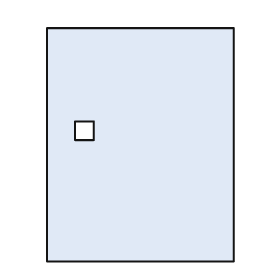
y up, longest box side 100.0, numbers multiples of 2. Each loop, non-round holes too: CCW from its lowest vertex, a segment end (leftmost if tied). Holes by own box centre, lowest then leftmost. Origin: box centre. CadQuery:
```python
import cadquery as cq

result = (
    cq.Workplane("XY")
    .moveTo(-40.0, -50.0)
    .lineTo(40.0, -50.0)
    .lineTo(40.0, 50.0)
    .lineTo(-40.0, 50.0)
    .close()
    .moveTo(-28.0, 2.0)
    .lineTo(-20.0, 2.0)
    .lineTo(-20.0, 10.0)
    .lineTo(-28.0, 10.0)
    .close()
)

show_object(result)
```